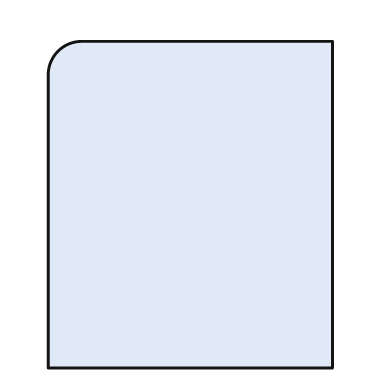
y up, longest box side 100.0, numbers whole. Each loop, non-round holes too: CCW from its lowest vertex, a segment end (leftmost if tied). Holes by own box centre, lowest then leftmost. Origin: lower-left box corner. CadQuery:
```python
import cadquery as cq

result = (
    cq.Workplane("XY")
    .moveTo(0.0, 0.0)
    .lineTo(87.0, 0.0)
    .lineTo(87.0, 100.0)
    .lineTo(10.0, 100.0)
    .threePointArc((3.0, 97.0), (0.0, 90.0))
    .close()
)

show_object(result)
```